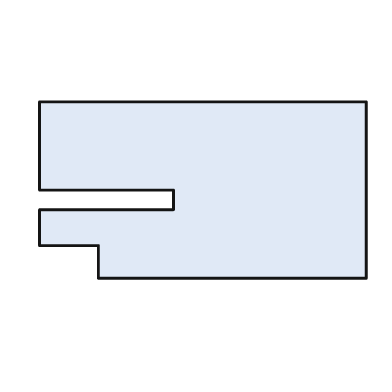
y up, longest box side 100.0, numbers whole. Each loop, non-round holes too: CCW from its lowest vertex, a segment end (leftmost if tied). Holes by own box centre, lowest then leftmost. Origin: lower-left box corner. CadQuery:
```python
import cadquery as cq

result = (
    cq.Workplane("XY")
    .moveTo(18.0, 0.0)
    .lineTo(100.0, 0.0)
    .lineTo(100.0, 54.0)
    .lineTo(0.0, 54.0)
    .lineTo(0.0, 27.0)
    .lineTo(41.0, 27.0)
    .lineTo(41.0, 21.0)
    .lineTo(0.0, 21.0)
    .lineTo(0.0, 10.0)
    .lineTo(18.0, 10.0)
    .close()
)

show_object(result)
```